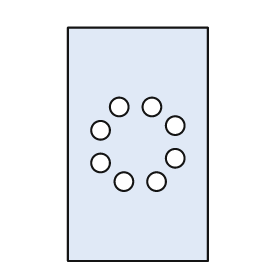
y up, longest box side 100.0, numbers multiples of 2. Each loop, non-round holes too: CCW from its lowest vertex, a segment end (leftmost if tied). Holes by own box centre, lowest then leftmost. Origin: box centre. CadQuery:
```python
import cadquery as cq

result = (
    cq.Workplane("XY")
    .moveTo(-30.0, -50.0)
    .lineTo(30.0, -50.0)
    .lineTo(30.0, 50.0)
    .lineTo(-30.0, 50.0)
    .close()
    .moveTo(-6.0, -16.0)
    .circle(4.0)
    .moveTo(8.0, -16.0)
    .circle(4.0)
    .moveTo(-16.0, -8.0)
    .circle(4.0)
    .moveTo(16.0, -6.0)
    .circle(4.0)
    .moveTo(-16.0, 6.0)
    .circle(4.0)
    .moveTo(16.0, 8.0)
    .circle(4.0)
    .moveTo(-8.0, 16.0)
    .circle(4.0)
    .moveTo(6.0, 16.0)
    .circle(4.0)
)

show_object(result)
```